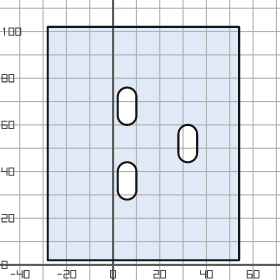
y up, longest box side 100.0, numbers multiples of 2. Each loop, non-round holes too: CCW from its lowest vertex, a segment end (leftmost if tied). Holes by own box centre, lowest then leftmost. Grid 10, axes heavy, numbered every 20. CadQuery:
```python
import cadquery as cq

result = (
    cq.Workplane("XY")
    .moveTo(-28.0, 2.0)
    .lineTo(54.0, 2.0)
    .lineTo(54.0, 102.0)
    .lineTo(-28.0, 102.0)
    .close()
    .moveTo(2.0, 32.0)
    .threePointArc((6.0, 28.0), (10.0, 32.0))
    .lineTo(10.0, 40.0)
    .threePointArc((6.0, 44.0), (2.0, 40.0))
    .close()
    .moveTo(28.0, 48.0)
    .threePointArc((32.0, 44.0), (36.0, 48.0))
    .lineTo(36.0, 56.0)
    .threePointArc((32.0, 60.0), (28.0, 56.0))
    .close()
    .moveTo(2.0, 64.0)
    .threePointArc((6.0, 60.0), (10.0, 64.0))
    .lineTo(10.0, 72.0)
    .threePointArc((6.0, 76.0), (2.0, 72.0))
    .close()
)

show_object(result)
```